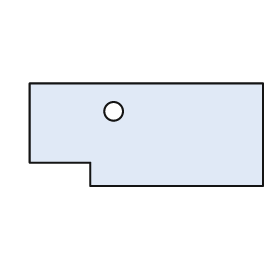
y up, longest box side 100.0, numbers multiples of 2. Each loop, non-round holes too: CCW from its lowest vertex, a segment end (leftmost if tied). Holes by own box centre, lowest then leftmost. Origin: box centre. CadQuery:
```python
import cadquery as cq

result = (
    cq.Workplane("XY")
    .moveTo(-24.0, -22.0)
    .lineTo(50.0, -22.0)
    .lineTo(50.0, 22.0)
    .lineTo(-50.0, 22.0)
    .lineTo(-50.0, -12.0)
    .lineTo(-24.0, -12.0)
    .close()
    .moveTo(-14.0, 10.0)
    .circle(4.0)
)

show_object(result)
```